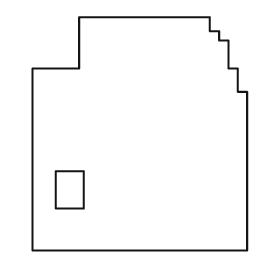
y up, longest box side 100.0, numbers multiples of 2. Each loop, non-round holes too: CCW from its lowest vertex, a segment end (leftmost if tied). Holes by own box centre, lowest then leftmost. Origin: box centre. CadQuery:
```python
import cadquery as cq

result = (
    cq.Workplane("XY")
    .moveTo(-46.0, -50.0)
    .lineTo(46.0, -50.0)
    .lineTo(46.0, 18.0)
    .lineTo(42.0, 18.0)
    .lineTo(42.0, 28.0)
    .lineTo(38.0, 28.0)
    .lineTo(38.0, 40.0)
    .lineTo(34.0, 40.0)
    .lineTo(34.0, 44.0)
    .lineTo(30.0, 44.0)
    .lineTo(30.0, 50.0)
    .lineTo(-26.0, 50.0)
    .lineTo(-26.0, 28.0)
    .lineTo(-46.0, 28.0)
    .close()
    .moveTo(-36.0, -32.0)
    .lineTo(-24.0, -32.0)
    .lineTo(-24.0, -16.0)
    .lineTo(-36.0, -16.0)
    .close()
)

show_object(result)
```